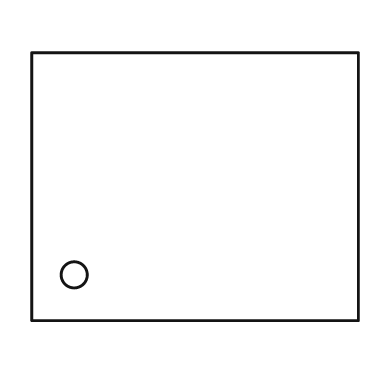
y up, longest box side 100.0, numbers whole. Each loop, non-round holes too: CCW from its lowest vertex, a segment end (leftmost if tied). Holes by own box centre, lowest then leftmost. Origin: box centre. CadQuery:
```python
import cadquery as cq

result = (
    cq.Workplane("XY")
    .moveTo(-50.0, -41.0)
    .lineTo(50.0, -41.0)
    .lineTo(50.0, 41.0)
    .lineTo(-50.0, 41.0)
    .close()
    .moveTo(-37.0, -27.0)
    .circle(4.0)
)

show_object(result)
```